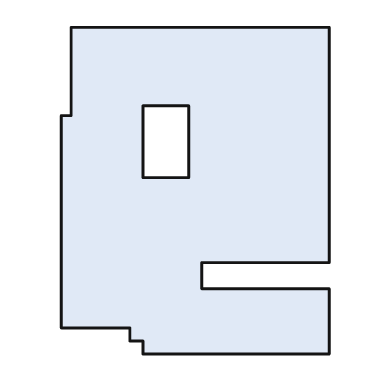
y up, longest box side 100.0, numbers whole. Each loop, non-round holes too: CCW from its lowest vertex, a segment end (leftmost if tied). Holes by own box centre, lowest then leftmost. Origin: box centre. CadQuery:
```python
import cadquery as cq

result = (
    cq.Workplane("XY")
    .moveTo(-16.0, -50.0)
    .lineTo(41.0, -50.0)
    .lineTo(41.0, -30.0)
    .lineTo(2.0, -30.0)
    .lineTo(2.0, -22.0)
    .lineTo(41.0, -22.0)
    .lineTo(41.0, 50.0)
    .lineTo(-38.0, 50.0)
    .lineTo(-38.0, 23.0)
    .lineTo(-41.0, 23.0)
    .lineTo(-41.0, -42.0)
    .lineTo(-20.0, -42.0)
    .lineTo(-20.0, -46.0)
    .lineTo(-16.0, -46.0)
    .close()
    .moveTo(-16.0, 4.0)
    .lineTo(-2.0, 4.0)
    .lineTo(-2.0, 26.0)
    .lineTo(-16.0, 26.0)
    .close()
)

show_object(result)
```